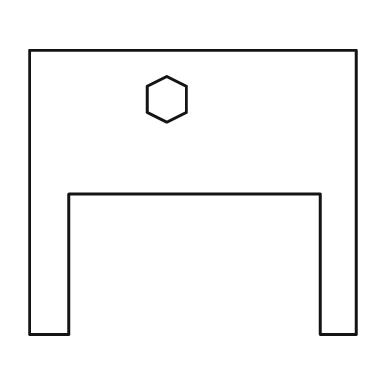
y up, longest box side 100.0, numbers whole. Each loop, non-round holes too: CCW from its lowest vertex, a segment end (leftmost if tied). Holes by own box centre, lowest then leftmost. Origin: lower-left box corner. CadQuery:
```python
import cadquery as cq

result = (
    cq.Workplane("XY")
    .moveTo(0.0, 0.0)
    .lineTo(12.0, 0.0)
    .lineTo(12.0, 43.0)
    .lineTo(89.0, 43.0)
    .lineTo(89.0, 0.0)
    .lineTo(100.0, 0.0)
    .lineTo(100.0, 87.0)
    .lineTo(0.0, 87.0)
    .close()
    .moveTo(42.0, 65.0)
    .lineTo(48.0, 68.0)
    .lineTo(48.0, 76.0)
    .lineTo(42.0, 79.0)
    .lineTo(36.0, 76.0)
    .lineTo(36.0, 68.0)
    .close()
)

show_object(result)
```